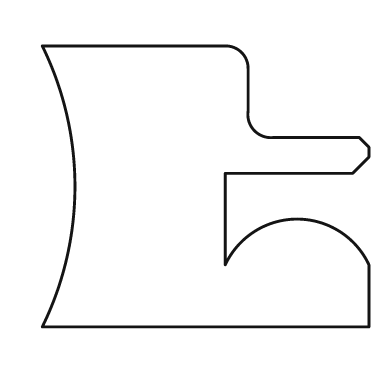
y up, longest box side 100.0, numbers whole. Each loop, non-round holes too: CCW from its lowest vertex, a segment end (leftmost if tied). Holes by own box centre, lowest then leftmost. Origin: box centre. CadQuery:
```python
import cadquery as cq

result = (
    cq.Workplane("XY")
    .moveTo(-50.0, -43.0)
    .lineTo(50.0, -43.0)
    .lineTo(50.0, -24.0)
    .threePointArc((28.0, -10.0), (6.0, -24.0))
    .lineTo(6.0, 4.0)
    .lineTo(45.0, 4.0)
    .lineTo(50.0, 9.0)
    .lineTo(50.0, 12.0)
    .lineTo(47.0, 15.0)
    .lineTo(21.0, 15.0)
    .threePointArc((15.0, 17.0), (13.0, 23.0))
    .lineTo(13.0, 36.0)
    .threePointArc((11.0, 41.0), (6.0, 43.0))
    .lineTo(-50.0, 43.0)
    .threePointArc((-40.0, 0.0), (-50.0, -43.0))
    .close()
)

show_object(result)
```